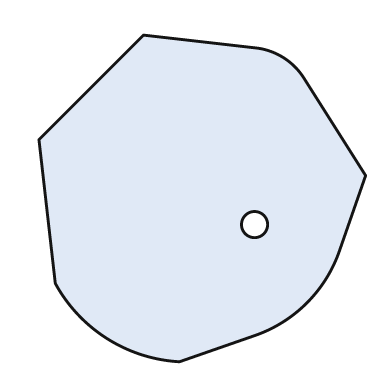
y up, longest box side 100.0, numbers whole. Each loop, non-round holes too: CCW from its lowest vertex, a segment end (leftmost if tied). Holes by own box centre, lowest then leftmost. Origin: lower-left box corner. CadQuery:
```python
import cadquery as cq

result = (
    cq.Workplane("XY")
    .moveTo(43.0, 0.0)
    .lineTo(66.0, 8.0)
    .threePointArc((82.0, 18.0), (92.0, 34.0))
    .lineTo(100.0, 57.0)
    .lineTo(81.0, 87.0)
    .threePointArc((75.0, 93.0), (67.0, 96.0))
    .lineTo(32.0, 100.0)
    .lineTo(0.0, 68.0)
    .lineTo(5.0, 24.0)
    .threePointArc((21.0, 7.0), (43.0, 0.0))
    .close()
    .moveTo(66.0, 42.0)
    .circle(4.0)
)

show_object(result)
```